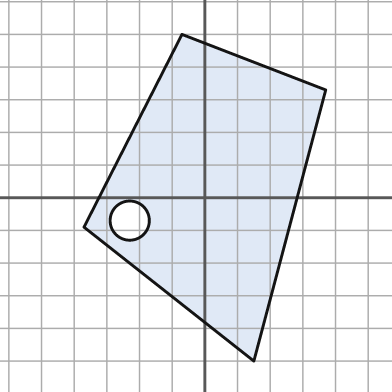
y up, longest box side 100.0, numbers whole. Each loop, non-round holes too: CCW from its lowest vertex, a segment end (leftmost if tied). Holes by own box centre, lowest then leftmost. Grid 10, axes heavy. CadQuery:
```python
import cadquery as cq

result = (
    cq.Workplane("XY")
    .moveTo(15.0, -50.0)
    .lineTo(37.0, 33.0)
    .lineTo(-7.0, 50.0)
    .lineTo(-37.0, -9.0)
    .close()
    .moveTo(-23.0, -7.0)
    .circle(6.0)
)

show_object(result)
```